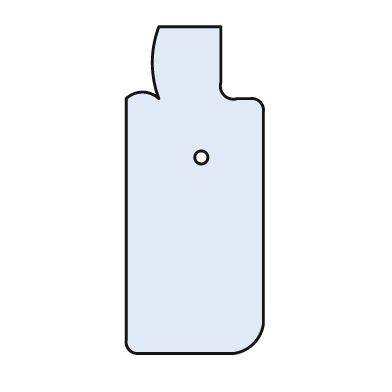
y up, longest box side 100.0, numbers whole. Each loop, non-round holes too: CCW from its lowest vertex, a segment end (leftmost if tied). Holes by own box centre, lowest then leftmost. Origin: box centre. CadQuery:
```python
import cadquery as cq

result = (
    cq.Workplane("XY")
    .moveTo(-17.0, -50.0)
    .lineTo(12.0, -50.0)
    .threePointArc((18.0, -47.0), (21.0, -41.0))
    .lineTo(21.0, 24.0)
    .threePointArc((20.0, 27.0), (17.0, 28.0))
    .lineTo(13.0, 28.0)
    .threePointArc((9.0, 29.0), (8.0, 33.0))
    .lineTo(8.0, 50.0)
    .lineTo(-11.0, 50.0)
    .threePointArc((-13.0, 39.0), (-11.0, 28.0))
    .threePointArc((-16.0, 30.0), (-21.0, 28.0))
    .lineTo(-21.0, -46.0)
    .threePointArc((-20.0, -49.0), (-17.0, -50.0))
    .close()
    .moveTo(2.0, 10.0)
    .circle(2.0)
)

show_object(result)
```